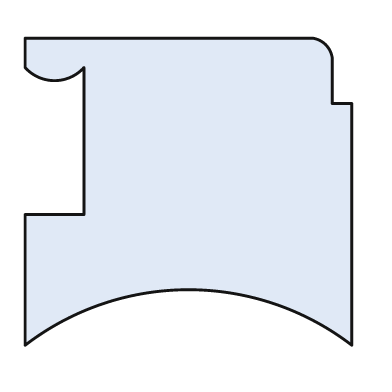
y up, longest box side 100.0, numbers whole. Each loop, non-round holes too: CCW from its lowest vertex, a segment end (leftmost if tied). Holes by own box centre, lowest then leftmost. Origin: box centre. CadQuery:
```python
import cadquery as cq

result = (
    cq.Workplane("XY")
    .moveTo(-50.0, -47.0)
    .threePointArc((0.0, -30.0), (50.0, -47.0))
    .lineTo(50.0, 27.0)
    .lineTo(44.0, 27.0)
    .lineTo(44.0, 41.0)
    .threePointArc((42.0, 45.0), (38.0, 47.0))
    .lineTo(-50.0, 47.0)
    .lineTo(-50.0, 38.0)
    .threePointArc((-41.0, 34.0), (-32.0, 38.0))
    .lineTo(-32.0, -7.0)
    .lineTo(-50.0, -7.0)
    .close()
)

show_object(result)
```